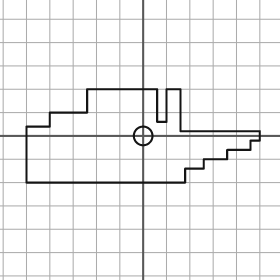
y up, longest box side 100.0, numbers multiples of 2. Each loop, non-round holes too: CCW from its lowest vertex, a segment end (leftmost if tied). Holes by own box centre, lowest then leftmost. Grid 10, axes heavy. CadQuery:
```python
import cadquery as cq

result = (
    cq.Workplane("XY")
    .moveTo(-50.0, -20.0)
    .lineTo(18.0, -20.0)
    .lineTo(18.0, -14.0)
    .lineTo(26.0, -14.0)
    .lineTo(26.0, -10.0)
    .lineTo(36.0, -10.0)
    .lineTo(36.0, -6.0)
    .lineTo(46.0, -6.0)
    .lineTo(46.0, -2.0)
    .lineTo(50.0, -2.0)
    .lineTo(50.0, 2.0)
    .lineTo(16.0, 2.0)
    .lineTo(16.0, 20.0)
    .lineTo(10.0, 20.0)
    .lineTo(10.0, 6.0)
    .lineTo(6.0, 6.0)
    .lineTo(6.0, 20.0)
    .lineTo(-24.0, 20.0)
    .lineTo(-24.0, 10.0)
    .lineTo(-40.0, 10.0)
    .lineTo(-40.0, 4.0)
    .lineTo(-50.0, 4.0)
    .close()
    .moveTo(0.0, 0.0)
    .circle(4.0)
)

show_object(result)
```